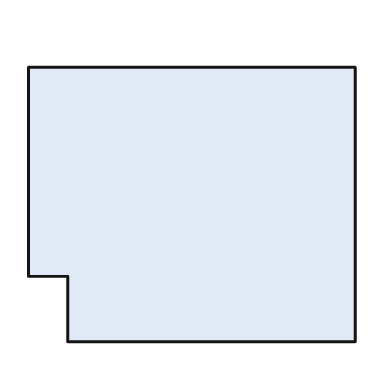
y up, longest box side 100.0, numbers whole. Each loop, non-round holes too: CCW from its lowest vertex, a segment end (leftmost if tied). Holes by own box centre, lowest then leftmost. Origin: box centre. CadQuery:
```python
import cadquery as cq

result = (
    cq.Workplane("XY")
    .moveTo(-38.0, -42.0)
    .lineTo(50.0, -42.0)
    .lineTo(50.0, 42.0)
    .lineTo(-50.0, 42.0)
    .lineTo(-50.0, -22.0)
    .lineTo(-38.0, -22.0)
    .close()
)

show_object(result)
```